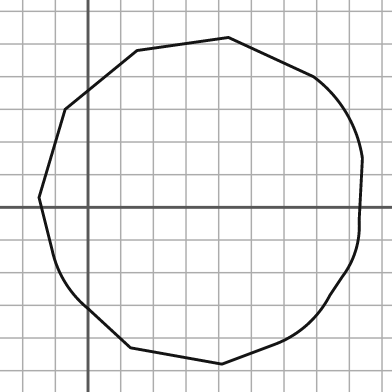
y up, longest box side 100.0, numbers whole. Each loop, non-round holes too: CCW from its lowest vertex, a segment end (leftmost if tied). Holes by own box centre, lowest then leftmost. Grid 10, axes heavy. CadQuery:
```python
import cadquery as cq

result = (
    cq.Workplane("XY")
    .moveTo(41.0, -48.0)
    .lineTo(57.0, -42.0)
    .threePointArc((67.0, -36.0), (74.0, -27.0))
    .lineTo(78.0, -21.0)
    .threePointArc((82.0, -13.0), (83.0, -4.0))
    .lineTo(84.0, 15.0)
    .threePointArc((79.0, 29.0), (69.0, 40.0))
    .lineTo(43.0, 52.0)
    .lineTo(15.0, 48.0)
    .lineTo(-7.0, 30.0)
    .lineTo(-15.0, 3.0)
    .lineTo(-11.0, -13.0)
    .threePointArc((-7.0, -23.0), (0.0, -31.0))
    .lineTo(13.0, -43.0)
    .close()
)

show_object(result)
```